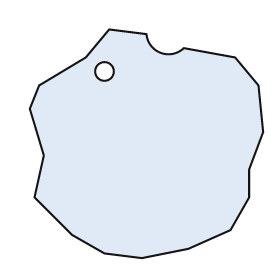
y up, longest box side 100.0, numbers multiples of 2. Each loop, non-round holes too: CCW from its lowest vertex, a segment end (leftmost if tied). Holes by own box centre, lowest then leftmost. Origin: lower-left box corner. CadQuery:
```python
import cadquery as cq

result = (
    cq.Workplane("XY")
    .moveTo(48.0, 0.0)
    .lineTo(68.0, 4.0)
    .lineTo(86.0, 12.0)
    .lineTo(94.0, 26.0)
    .lineTo(94.0, 38.0)
    .lineTo(100.0, 54.0)
    .lineTo(98.0, 74.0)
    .lineTo(88.0, 86.0)
    .lineTo(66.0, 90.0)
    .threePointArc((56.0, 88.0), (50.0, 96.0))
    .lineTo(34.0, 98.0)
    .lineTo(24.0, 86.0)
    .lineTo(4.0, 74.0)
    .lineTo(0.0, 64.0)
    .lineTo(6.0, 44.0)
    .lineTo(2.0, 26.0)
    .lineTo(18.0, 10.0)
    .lineTo(32.0, 2.0)
    .close()
    .moveTo(32.0, 80.0)
    .circle(4.0)
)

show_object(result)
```